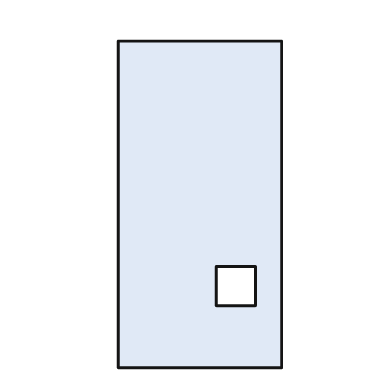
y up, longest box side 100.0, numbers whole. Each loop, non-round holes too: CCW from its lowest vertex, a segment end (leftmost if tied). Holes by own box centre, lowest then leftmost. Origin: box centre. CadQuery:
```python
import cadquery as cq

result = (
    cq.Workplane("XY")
    .moveTo(-25.0, -50.0)
    .lineTo(25.0, -50.0)
    .lineTo(25.0, 50.0)
    .lineTo(-25.0, 50.0)
    .close()
    .moveTo(5.0, -31.0)
    .lineTo(17.0, -31.0)
    .lineTo(17.0, -19.0)
    .lineTo(5.0, -19.0)
    .close()
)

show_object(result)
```